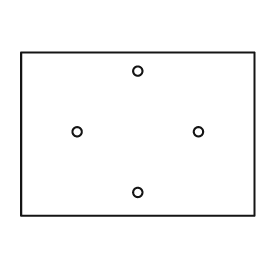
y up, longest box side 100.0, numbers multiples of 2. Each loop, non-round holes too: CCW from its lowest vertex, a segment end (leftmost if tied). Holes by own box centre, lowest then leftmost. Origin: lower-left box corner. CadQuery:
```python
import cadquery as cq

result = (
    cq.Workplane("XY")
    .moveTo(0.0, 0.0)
    .lineTo(100.0, 0.0)
    .lineTo(100.0, 70.0)
    .lineTo(0.0, 70.0)
    .close()
    .moveTo(50.0, 10.0)
    .circle(2.0)
    .moveTo(24.0, 36.0)
    .circle(2.0)
    .moveTo(76.0, 36.0)
    .circle(2.0)
    .moveTo(50.0, 62.0)
    .circle(2.0)
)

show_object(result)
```